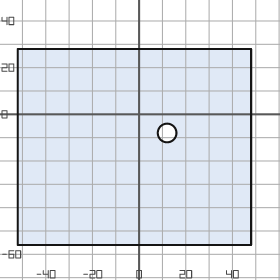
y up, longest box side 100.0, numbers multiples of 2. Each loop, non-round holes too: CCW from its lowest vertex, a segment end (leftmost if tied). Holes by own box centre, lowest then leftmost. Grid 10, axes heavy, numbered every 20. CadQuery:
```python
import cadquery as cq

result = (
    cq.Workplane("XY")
    .moveTo(-52.0, -56.0)
    .lineTo(48.0, -56.0)
    .lineTo(48.0, 28.0)
    .lineTo(-52.0, 28.0)
    .close()
    .moveTo(12.0, -8.0)
    .circle(4.0)
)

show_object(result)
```